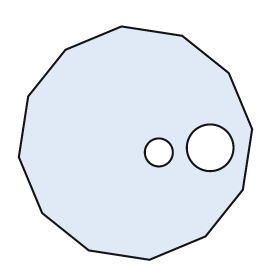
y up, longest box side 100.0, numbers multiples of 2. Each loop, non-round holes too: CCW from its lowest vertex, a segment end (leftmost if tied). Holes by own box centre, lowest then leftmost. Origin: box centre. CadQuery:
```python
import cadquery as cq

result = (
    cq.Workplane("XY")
    .moveTo(6.0, -50.0)
    .lineTo(30.0, -40.0)
    .lineTo(46.0, -20.0)
    .lineTo(50.0, 6.0)
    .lineTo(40.0, 30.0)
    .lineTo(20.0, 46.0)
    .lineTo(-6.0, 50.0)
    .lineTo(-30.0, 40.0)
    .lineTo(-46.0, 20.0)
    .lineTo(-50.0, -6.0)
    .lineTo(-40.0, -30.0)
    .lineTo(-20.0, -46.0)
    .close()
    .moveTo(10.0, -4.0)
    .circle(6.0)
    .moveTo(32.0, -2.0)
    .circle(10.0)
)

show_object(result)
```